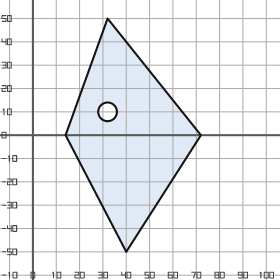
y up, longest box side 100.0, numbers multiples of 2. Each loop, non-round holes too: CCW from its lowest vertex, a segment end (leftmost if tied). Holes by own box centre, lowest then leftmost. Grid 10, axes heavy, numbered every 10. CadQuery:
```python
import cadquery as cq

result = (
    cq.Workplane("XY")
    .moveTo(40.0, -50.0)
    .lineTo(72.0, 0.0)
    .lineTo(32.0, 50.0)
    .lineTo(14.0, 0.0)
    .close()
    .moveTo(32.0, 10.0)
    .circle(4.0)
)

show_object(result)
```